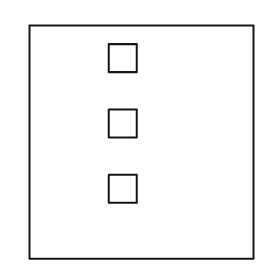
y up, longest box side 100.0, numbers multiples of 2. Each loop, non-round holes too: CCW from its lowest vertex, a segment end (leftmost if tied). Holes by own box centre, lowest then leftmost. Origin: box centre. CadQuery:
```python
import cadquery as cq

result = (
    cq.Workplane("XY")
    .moveTo(-48.0, -50.0)
    .lineTo(48.0, -50.0)
    .lineTo(48.0, 50.0)
    .lineTo(-48.0, 50.0)
    .close()
    .moveTo(-14.0, -26.0)
    .lineTo(-2.0, -26.0)
    .lineTo(-2.0, -14.0)
    .lineTo(-14.0, -14.0)
    .close()
    .moveTo(-14.0, 2.0)
    .lineTo(-2.0, 2.0)
    .lineTo(-2.0, 14.0)
    .lineTo(-14.0, 14.0)
    .close()
    .moveTo(-14.0, 30.0)
    .lineTo(-2.0, 30.0)
    .lineTo(-2.0, 42.0)
    .lineTo(-14.0, 42.0)
    .close()
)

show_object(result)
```